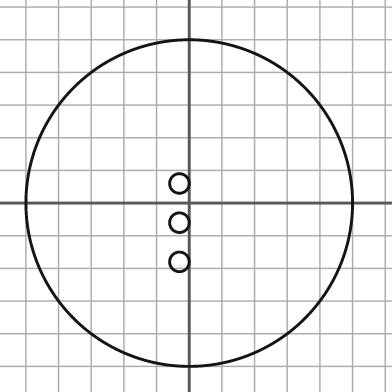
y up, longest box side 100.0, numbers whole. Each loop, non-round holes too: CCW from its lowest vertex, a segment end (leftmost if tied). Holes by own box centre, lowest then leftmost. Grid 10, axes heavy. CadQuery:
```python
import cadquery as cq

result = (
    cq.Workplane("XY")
    .moveTo(0.0, 0.0)
    .circle(50.0)
    .moveTo(-3.0, -18.0)
    .circle(3.0)
    .moveTo(-3.0, -6.0)
    .circle(3.0)
    .moveTo(-3.0, 6.0)
    .circle(3.0)
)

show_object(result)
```